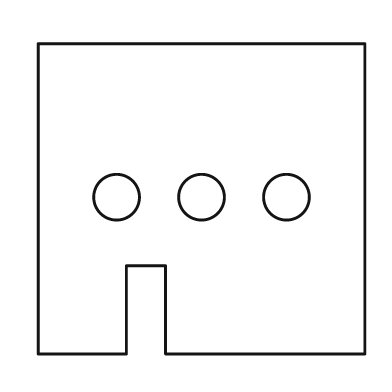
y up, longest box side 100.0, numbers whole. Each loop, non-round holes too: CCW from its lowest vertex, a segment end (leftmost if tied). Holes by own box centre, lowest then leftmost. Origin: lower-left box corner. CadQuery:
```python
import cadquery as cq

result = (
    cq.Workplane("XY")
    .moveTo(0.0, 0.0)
    .lineTo(27.0, 0.0)
    .lineTo(27.0, 27.0)
    .lineTo(39.0, 27.0)
    .lineTo(39.0, 0.0)
    .lineTo(100.0, 0.0)
    .lineTo(100.0, 95.0)
    .lineTo(0.0, 95.0)
    .close()
    .moveTo(24.0, 48.0)
    .circle(7.0)
    .moveTo(50.0, 48.0)
    .circle(7.0)
    .moveTo(76.0, 48.0)
    .circle(7.0)
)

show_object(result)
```